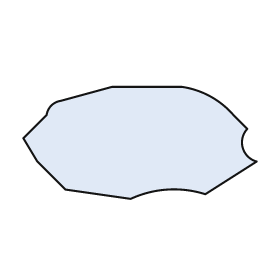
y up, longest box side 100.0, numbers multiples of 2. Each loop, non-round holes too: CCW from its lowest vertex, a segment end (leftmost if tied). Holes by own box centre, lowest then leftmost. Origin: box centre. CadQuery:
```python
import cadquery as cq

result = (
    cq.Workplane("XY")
    .moveTo(-4.0, -24.0)
    .threePointArc((12.0, -20.0), (28.0, -22.0))
    .lineTo(50.0, -8.0)
    .threePointArc((44.0, -2.0), (46.0, 6.0))
    .lineTo(40.0, 12.0)
    .threePointArc((30.0, 20.0), (18.0, 24.0))
    .lineTo(-12.0, 24.0)
    .lineTo(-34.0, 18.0)
    .threePointArc((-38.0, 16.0), (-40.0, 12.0))
    .lineTo(-50.0, 2.0)
    .lineTo(-44.0, -8.0)
    .lineTo(-32.0, -20.0)
    .close()
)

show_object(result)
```